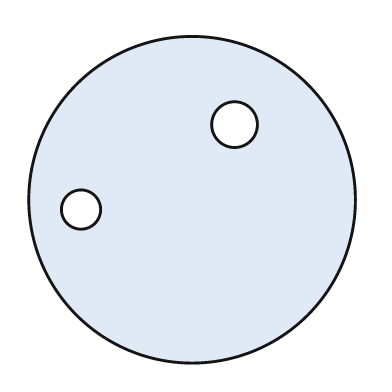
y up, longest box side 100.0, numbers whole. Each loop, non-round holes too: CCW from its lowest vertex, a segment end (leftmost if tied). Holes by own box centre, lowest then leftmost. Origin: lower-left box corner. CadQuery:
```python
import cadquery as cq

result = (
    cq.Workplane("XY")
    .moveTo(50.0, 50.0)
    .circle(50.0)
    .moveTo(16.0, 47.0)
    .circle(6.0)
    .moveTo(63.0, 73.0)
    .circle(7.0)
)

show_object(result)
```